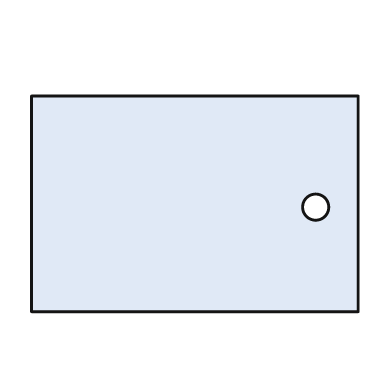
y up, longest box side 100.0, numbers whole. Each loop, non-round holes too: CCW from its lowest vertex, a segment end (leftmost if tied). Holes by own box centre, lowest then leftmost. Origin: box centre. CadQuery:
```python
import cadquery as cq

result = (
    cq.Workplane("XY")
    .moveTo(-50.0, -33.0)
    .lineTo(50.0, -33.0)
    .lineTo(50.0, 33.0)
    .lineTo(-50.0, 33.0)
    .close()
    .moveTo(37.0, -1.0)
    .circle(4.0)
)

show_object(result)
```